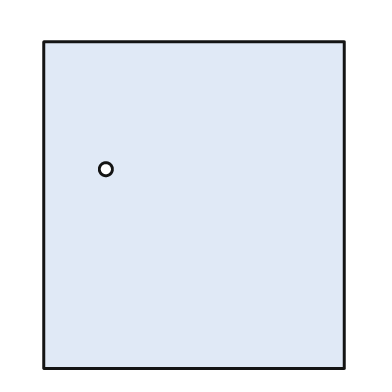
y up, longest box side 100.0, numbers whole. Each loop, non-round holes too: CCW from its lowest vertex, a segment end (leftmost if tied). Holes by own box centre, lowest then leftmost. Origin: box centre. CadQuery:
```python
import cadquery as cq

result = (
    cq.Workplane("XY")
    .moveTo(-46.0, -50.0)
    .lineTo(46.0, -50.0)
    .lineTo(46.0, 50.0)
    .lineTo(-46.0, 50.0)
    .close()
    .moveTo(-27.0, 11.0)
    .circle(2.0)
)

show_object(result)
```